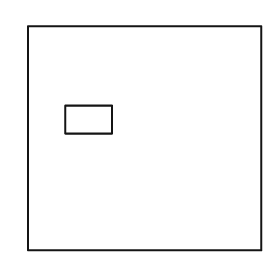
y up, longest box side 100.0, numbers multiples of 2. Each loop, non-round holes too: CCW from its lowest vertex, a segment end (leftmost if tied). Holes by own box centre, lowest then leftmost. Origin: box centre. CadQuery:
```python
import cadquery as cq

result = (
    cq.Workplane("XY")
    .moveTo(-50.0, -48.0)
    .lineTo(50.0, -48.0)
    .lineTo(50.0, 48.0)
    .lineTo(-50.0, 48.0)
    .close()
    .moveTo(-34.0, 2.0)
    .lineTo(-14.0, 2.0)
    .lineTo(-14.0, 14.0)
    .lineTo(-34.0, 14.0)
    .close()
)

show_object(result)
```